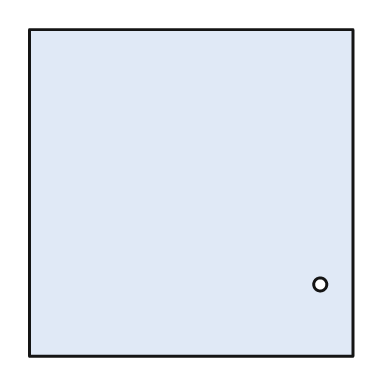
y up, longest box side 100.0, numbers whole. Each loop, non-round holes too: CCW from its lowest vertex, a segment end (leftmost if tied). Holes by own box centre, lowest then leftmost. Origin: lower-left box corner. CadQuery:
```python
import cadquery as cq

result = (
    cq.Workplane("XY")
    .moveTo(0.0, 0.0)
    .lineTo(99.0, 0.0)
    .lineTo(99.0, 100.0)
    .lineTo(0.0, 100.0)
    .close()
    .moveTo(89.0, 22.0)
    .circle(2.0)
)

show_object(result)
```